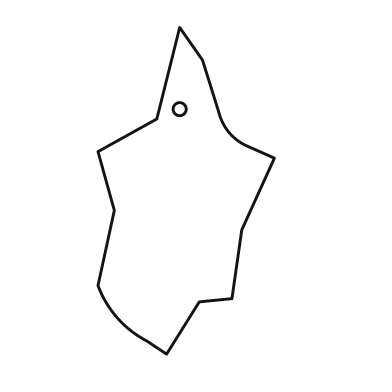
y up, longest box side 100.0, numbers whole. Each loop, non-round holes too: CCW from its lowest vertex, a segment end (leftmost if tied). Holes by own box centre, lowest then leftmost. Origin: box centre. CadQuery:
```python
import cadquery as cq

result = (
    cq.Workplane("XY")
    .moveTo(-6.0, -50.0)
    .lineTo(4.0, -34.0)
    .lineTo(14.0, -33.0)
    .lineTo(17.0, -12.0)
    .lineTo(27.0, 10.0)
    .lineTo(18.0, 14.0)
    .threePointArc((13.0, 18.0), (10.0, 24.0))
    .lineTo(5.0, 40.0)
    .lineTo(-2.0, 50.0)
    .lineTo(-9.0, 22.0)
    .lineTo(-27.0, 12.0)
    .lineTo(-22.0, -6.0)
    .lineTo(-27.0, -29.0)
    .threePointArc((-21.0, -39.0), (-12.0, -46.0))
    .close()
    .moveTo(-2.0, 25.0)
    .circle(2.0)
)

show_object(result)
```